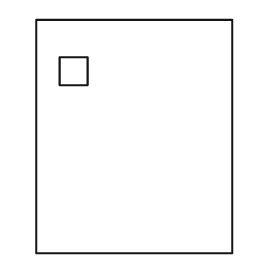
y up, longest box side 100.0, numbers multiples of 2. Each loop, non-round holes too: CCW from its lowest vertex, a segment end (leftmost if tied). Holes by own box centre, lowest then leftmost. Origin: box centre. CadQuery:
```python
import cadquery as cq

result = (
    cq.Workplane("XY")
    .moveTo(-42.0, -50.0)
    .lineTo(42.0, -50.0)
    .lineTo(42.0, 50.0)
    .lineTo(-42.0, 50.0)
    .close()
    .moveTo(-32.0, 22.0)
    .lineTo(-20.0, 22.0)
    .lineTo(-20.0, 34.0)
    .lineTo(-32.0, 34.0)
    .close()
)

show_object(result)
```